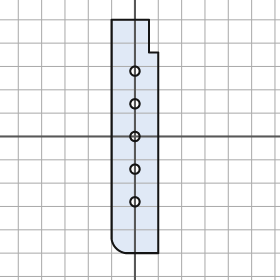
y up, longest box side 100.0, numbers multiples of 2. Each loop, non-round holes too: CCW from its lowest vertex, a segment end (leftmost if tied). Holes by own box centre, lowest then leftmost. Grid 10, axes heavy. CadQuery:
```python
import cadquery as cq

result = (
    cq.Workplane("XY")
    .moveTo(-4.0, -50.0)
    .lineTo(10.0, -50.0)
    .lineTo(10.0, 36.0)
    .lineTo(6.0, 36.0)
    .lineTo(6.0, 50.0)
    .lineTo(-10.0, 50.0)
    .lineTo(-10.0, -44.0)
    .threePointArc((-8.0, -48.0), (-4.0, -50.0))
    .close()
    .moveTo(0.0, -28.0)
    .circle(2.0)
    .moveTo(0.0, -14.0)
    .circle(2.0)
    .moveTo(0.0, 0.0)
    .circle(2.0)
    .moveTo(0.0, 14.0)
    .circle(2.0)
    .moveTo(0.0, 28.0)
    .circle(2.0)
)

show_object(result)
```